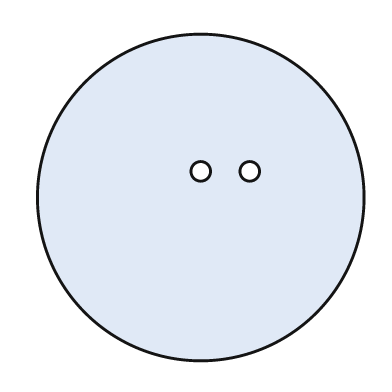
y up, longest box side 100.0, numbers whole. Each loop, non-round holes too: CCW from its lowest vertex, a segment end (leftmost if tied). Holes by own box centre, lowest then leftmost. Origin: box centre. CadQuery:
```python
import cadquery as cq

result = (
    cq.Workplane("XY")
    .moveTo(0.0, 0.0)
    .circle(50.0)
    .moveTo(0.0, 8.0)
    .circle(3.0)
    .moveTo(15.0, 8.0)
    .circle(3.0)
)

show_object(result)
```